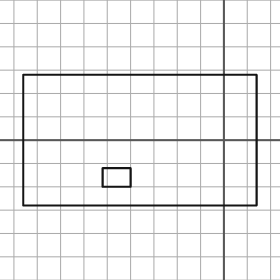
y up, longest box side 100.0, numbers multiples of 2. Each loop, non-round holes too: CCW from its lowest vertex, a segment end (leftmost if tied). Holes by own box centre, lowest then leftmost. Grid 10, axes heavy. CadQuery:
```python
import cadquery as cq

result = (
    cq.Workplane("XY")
    .moveTo(-86.0, -28.0)
    .lineTo(14.0, -28.0)
    .lineTo(14.0, 28.0)
    .lineTo(-86.0, 28.0)
    .close()
    .moveTo(-52.0, -20.0)
    .lineTo(-40.0, -20.0)
    .lineTo(-40.0, -12.0)
    .lineTo(-52.0, -12.0)
    .close()
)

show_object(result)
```